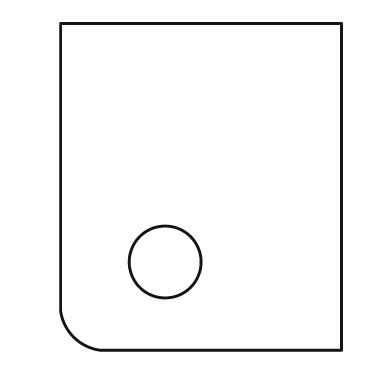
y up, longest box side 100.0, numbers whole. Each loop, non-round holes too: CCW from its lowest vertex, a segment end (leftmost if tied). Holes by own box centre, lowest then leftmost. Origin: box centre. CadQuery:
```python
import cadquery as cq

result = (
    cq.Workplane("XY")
    .moveTo(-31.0, -50.0)
    .lineTo(43.0, -50.0)
    .lineTo(43.0, 50.0)
    .lineTo(-43.0, 50.0)
    .lineTo(-43.0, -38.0)
    .threePointArc((-39.0, -46.0), (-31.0, -50.0))
    .close()
    .moveTo(-11.0, -23.0)
    .circle(11.0)
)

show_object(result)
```